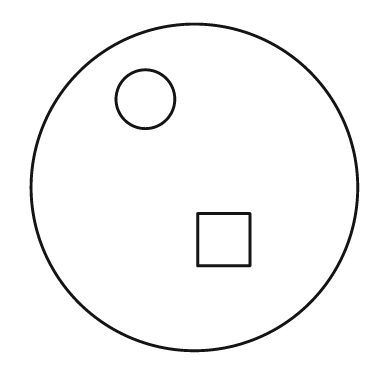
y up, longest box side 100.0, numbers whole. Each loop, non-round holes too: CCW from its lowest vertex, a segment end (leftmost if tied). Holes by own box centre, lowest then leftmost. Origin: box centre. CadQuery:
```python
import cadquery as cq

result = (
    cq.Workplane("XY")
    .moveTo(0.0, 0.0)
    .circle(50.0)
    .moveTo(1.0, -24.0)
    .lineTo(17.0, -24.0)
    .lineTo(17.0, -8.0)
    .lineTo(1.0, -8.0)
    .close()
    .moveTo(-15.0, 27.0)
    .circle(9.0)
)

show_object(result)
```